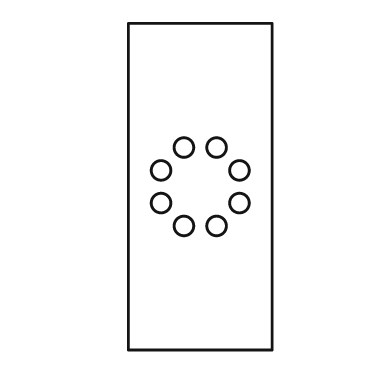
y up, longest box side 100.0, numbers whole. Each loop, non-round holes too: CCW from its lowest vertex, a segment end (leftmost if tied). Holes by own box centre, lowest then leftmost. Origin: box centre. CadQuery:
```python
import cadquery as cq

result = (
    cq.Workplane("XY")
    .moveTo(-22.0, -50.0)
    .lineTo(22.0, -50.0)
    .lineTo(22.0, 50.0)
    .lineTo(-22.0, 50.0)
    .close()
    .moveTo(-5.0, -12.0)
    .circle(3.0)
    .moveTo(5.0, -12.0)
    .circle(3.0)
    .moveTo(-12.0, -5.0)
    .circle(3.0)
    .moveTo(12.0, -5.0)
    .circle(3.0)
    .moveTo(-12.0, 5.0)
    .circle(3.0)
    .moveTo(12.0, 5.0)
    .circle(3.0)
    .moveTo(-5.0, 12.0)
    .circle(3.0)
    .moveTo(5.0, 12.0)
    .circle(3.0)
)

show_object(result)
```